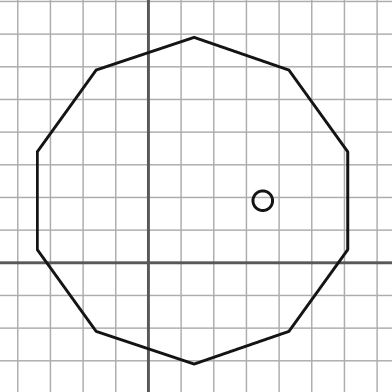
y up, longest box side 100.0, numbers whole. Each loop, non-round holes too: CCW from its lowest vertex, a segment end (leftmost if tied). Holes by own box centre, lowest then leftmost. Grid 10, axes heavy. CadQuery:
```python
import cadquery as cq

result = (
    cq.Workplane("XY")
    .moveTo(14.0, -31.0)
    .lineTo(43.0, -21.0)
    .lineTo(61.0, 4.0)
    .lineTo(61.0, 34.0)
    .lineTo(43.0, 59.0)
    .lineTo(14.0, 69.0)
    .lineTo(-16.0, 59.0)
    .lineTo(-34.0, 34.0)
    .lineTo(-34.0, 4.0)
    .lineTo(-16.0, -21.0)
    .close()
    .moveTo(35.0, 19.0)
    .circle(3.0)
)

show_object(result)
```